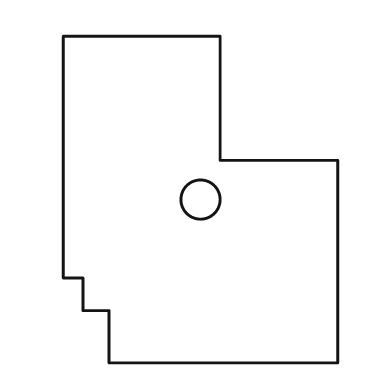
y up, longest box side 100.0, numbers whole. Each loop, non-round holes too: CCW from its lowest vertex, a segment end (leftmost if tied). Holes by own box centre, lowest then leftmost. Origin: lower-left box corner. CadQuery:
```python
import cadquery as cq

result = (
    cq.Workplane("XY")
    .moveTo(14.0, 0.0)
    .lineTo(84.0, 0.0)
    .lineTo(84.0, 62.0)
    .lineTo(48.0, 62.0)
    .lineTo(48.0, 100.0)
    .lineTo(0.0, 100.0)
    .lineTo(0.0, 26.0)
    .lineTo(6.0, 26.0)
    .lineTo(6.0, 16.0)
    .lineTo(14.0, 16.0)
    .close()
    .moveTo(42.0, 50.0)
    .circle(6.0)
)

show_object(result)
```